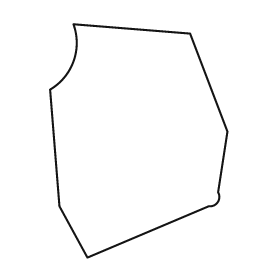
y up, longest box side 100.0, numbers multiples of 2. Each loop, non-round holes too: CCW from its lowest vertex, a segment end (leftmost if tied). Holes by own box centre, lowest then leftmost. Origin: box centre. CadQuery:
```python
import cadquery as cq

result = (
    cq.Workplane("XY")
    .moveTo(-22.0, -50.0)
    .lineTo(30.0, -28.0)
    .threePointArc((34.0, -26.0), (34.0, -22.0))
    .lineTo(38.0, 4.0)
    .lineTo(22.0, 46.0)
    .lineTo(-28.0, 50.0)
    .threePointArc((-28.0, 34.0), (-38.0, 22.0))
    .lineTo(-34.0, -28.0)
    .close()
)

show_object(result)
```